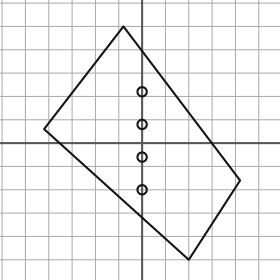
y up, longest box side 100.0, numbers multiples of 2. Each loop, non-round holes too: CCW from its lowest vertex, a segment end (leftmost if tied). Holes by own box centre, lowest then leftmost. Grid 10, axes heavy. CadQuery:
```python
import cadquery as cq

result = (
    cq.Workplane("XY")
    .moveTo(20.0, -50.0)
    .lineTo(42.0, -16.0)
    .lineTo(-8.0, 50.0)
    .lineTo(-42.0, 6.0)
    .close()
    .moveTo(0.0, -20.0)
    .circle(2.0)
    .moveTo(0.0, -6.0)
    .circle(2.0)
    .moveTo(0.0, 8.0)
    .circle(2.0)
    .moveTo(0.0, 22.0)
    .circle(2.0)
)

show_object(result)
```